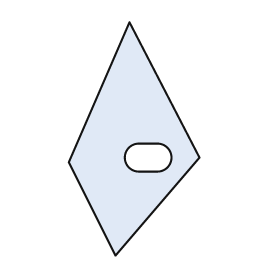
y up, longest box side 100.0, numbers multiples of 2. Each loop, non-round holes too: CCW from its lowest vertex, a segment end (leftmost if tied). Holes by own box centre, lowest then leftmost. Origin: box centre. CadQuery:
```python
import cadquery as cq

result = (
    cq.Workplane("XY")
    .moveTo(-8.0, -50.0)
    .lineTo(28.0, -8.0)
    .lineTo(-2.0, 50.0)
    .lineTo(-28.0, -10.0)
    .close()
    .moveTo(2.0, -14.0)
    .lineTo(10.0, -14.0)
    .threePointArc((16.0, -8.0), (10.0, -2.0))
    .lineTo(2.0, -2.0)
    .threePointArc((-4.0, -8.0), (2.0, -14.0))
    .close()
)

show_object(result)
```